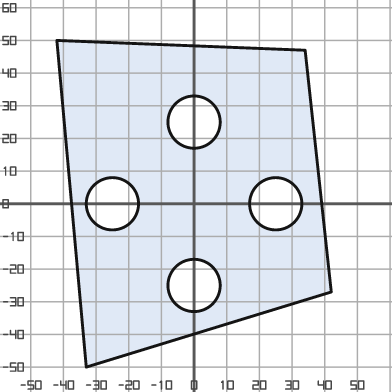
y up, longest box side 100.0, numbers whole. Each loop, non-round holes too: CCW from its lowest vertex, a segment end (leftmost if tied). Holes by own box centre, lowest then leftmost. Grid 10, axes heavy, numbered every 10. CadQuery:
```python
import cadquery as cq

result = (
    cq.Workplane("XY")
    .moveTo(-33.0, -50.0)
    .lineTo(42.0, -27.0)
    .lineTo(34.0, 47.0)
    .lineTo(-42.0, 50.0)
    .close()
    .moveTo(0.0, -25.0)
    .circle(8.0)
    .moveTo(-25.0, 0.0)
    .circle(8.0)
    .moveTo(25.0, 0.0)
    .circle(8.0)
    .moveTo(0.0, 25.0)
    .circle(8.0)
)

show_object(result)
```